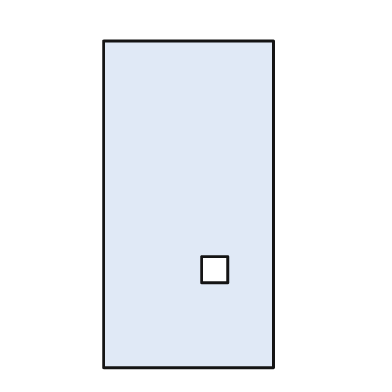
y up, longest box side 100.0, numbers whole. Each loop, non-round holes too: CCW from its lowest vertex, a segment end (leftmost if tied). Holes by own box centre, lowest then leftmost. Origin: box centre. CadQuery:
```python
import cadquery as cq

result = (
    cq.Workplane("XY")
    .moveTo(-26.0, -50.0)
    .lineTo(26.0, -50.0)
    .lineTo(26.0, 50.0)
    .lineTo(-26.0, 50.0)
    .close()
    .moveTo(4.0, -24.0)
    .lineTo(12.0, -24.0)
    .lineTo(12.0, -16.0)
    .lineTo(4.0, -16.0)
    .close()
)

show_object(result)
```